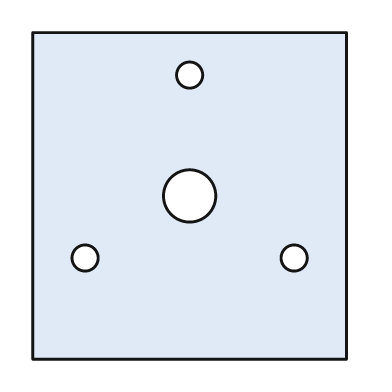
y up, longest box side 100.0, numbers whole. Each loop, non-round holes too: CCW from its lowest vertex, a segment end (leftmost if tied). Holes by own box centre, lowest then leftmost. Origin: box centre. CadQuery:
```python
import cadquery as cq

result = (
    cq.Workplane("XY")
    .moveTo(-48.0, -50.0)
    .lineTo(48.0, -50.0)
    .lineTo(48.0, 50.0)
    .lineTo(-48.0, 50.0)
    .close()
    .moveTo(-32.0, -19.0)
    .circle(4.0)
    .moveTo(32.0, -19.0)
    .circle(4.0)
    .moveTo(0.0, 0.0)
    .circle(8.0)
    .moveTo(0.0, 37.0)
    .circle(4.0)
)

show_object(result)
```